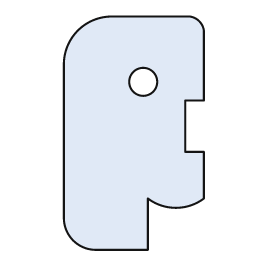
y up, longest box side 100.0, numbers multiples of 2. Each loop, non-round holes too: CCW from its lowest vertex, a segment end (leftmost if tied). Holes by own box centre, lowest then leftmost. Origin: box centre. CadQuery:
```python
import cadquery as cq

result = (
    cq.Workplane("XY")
    .moveTo(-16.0, -50.0)
    .lineTo(6.0, -50.0)
    .lineTo(6.0, -28.0)
    .threePointArc((18.0, -32.0), (30.0, -28.0))
    .lineTo(30.0, -8.0)
    .lineTo(22.0, -8.0)
    .lineTo(22.0, 14.0)
    .lineTo(30.0, 14.0)
    .lineTo(30.0, 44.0)
    .threePointArc((28.0, 48.0), (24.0, 50.0))
    .lineTo(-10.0, 50.0)
    .threePointArc((-24.0, 44.0), (-30.0, 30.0))
    .lineTo(-30.0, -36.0)
    .threePointArc((-26.0, -46.0), (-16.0, -50.0))
    .close()
    .moveTo(4.0, 22.0)
    .circle(6.0)
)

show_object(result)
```